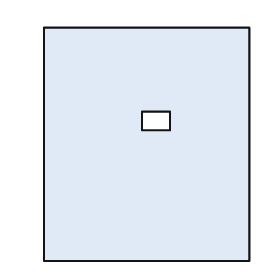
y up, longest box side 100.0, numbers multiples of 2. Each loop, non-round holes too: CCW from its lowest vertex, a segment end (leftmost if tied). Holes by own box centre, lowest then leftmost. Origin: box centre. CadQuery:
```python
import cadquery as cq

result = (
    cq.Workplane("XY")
    .moveTo(-44.0, -50.0)
    .lineTo(44.0, -50.0)
    .lineTo(44.0, 50.0)
    .lineTo(-44.0, 50.0)
    .close()
    .moveTo(-2.0, 6.0)
    .lineTo(10.0, 6.0)
    .lineTo(10.0, 14.0)
    .lineTo(-2.0, 14.0)
    .close()
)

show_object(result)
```